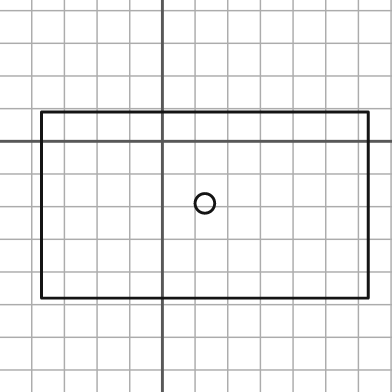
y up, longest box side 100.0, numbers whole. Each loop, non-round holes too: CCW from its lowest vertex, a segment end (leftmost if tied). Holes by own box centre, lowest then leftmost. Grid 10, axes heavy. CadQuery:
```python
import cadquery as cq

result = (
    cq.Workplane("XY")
    .moveTo(-37.0, -48.0)
    .lineTo(63.0, -48.0)
    .lineTo(63.0, 9.0)
    .lineTo(-37.0, 9.0)
    .close()
    .moveTo(13.0, -19.0)
    .circle(3.0)
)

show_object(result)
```